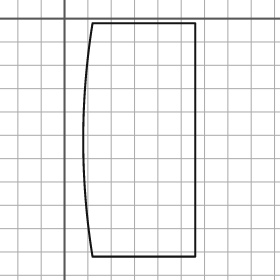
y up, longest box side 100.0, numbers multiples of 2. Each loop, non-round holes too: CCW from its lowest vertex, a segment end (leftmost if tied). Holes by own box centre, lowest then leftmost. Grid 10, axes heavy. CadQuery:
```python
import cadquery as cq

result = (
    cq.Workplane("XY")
    .moveTo(12.0, -102.0)
    .lineTo(56.0, -102.0)
    .lineTo(56.0, -2.0)
    .lineTo(12.0, -2.0)
    .threePointArc((8.0, -52.0), (12.0, -102.0))
    .close()
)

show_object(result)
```